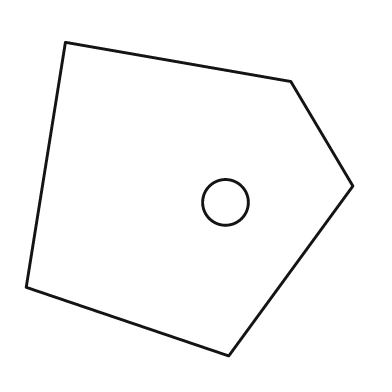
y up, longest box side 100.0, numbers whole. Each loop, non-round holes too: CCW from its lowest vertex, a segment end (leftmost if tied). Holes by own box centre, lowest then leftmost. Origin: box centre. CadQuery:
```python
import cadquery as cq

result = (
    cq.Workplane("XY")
    .moveTo(12.0, -48.0)
    .lineTo(50.0, 4.0)
    .lineTo(31.0, 36.0)
    .lineTo(-38.0, 48.0)
    .lineTo(-50.0, -27.0)
    .close()
    .moveTo(11.0, -1.0)
    .circle(7.0)
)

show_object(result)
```